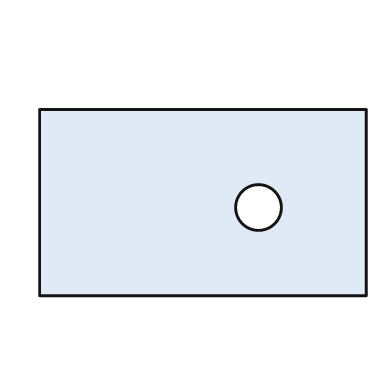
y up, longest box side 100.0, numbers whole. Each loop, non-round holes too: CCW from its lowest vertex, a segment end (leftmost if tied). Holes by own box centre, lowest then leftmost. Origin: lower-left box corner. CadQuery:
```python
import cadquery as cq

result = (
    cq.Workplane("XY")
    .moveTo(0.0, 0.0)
    .lineTo(100.0, 0.0)
    .lineTo(100.0, 57.0)
    .lineTo(0.0, 57.0)
    .close()
    .moveTo(67.0, 27.0)
    .circle(7.0)
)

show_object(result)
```